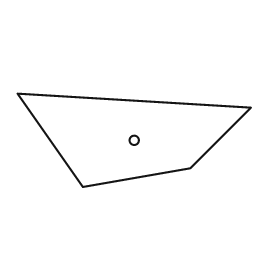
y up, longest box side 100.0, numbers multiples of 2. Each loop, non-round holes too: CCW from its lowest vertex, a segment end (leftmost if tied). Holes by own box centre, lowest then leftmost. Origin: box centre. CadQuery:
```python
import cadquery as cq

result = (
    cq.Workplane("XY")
    .moveTo(-22.0, -20.0)
    .lineTo(24.0, -12.0)
    .lineTo(50.0, 14.0)
    .lineTo(-50.0, 20.0)
    .close()
    .moveTo(0.0, 0.0)
    .circle(2.0)
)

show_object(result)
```